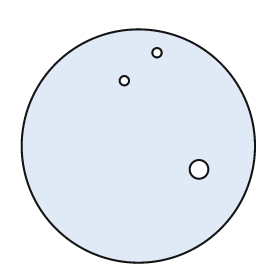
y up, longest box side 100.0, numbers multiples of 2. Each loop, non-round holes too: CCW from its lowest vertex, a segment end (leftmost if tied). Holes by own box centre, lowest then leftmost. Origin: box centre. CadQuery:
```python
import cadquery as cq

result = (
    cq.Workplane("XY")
    .moveTo(0.0, 0.0)
    .circle(50.0)
    .moveTo(26.0, -10.0)
    .circle(4.0)
    .moveTo(-6.0, 28.0)
    .circle(2.0)
    .moveTo(8.0, 40.0)
    .circle(2.0)
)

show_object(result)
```